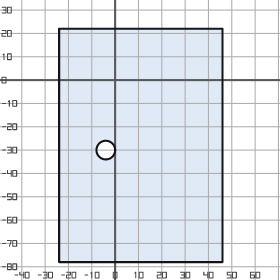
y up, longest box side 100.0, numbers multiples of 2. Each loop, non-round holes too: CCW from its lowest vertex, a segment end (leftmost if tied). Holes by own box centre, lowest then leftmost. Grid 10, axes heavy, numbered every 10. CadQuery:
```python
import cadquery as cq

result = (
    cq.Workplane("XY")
    .moveTo(-24.0, -78.0)
    .lineTo(46.0, -78.0)
    .lineTo(46.0, 22.0)
    .lineTo(-24.0, 22.0)
    .close()
    .moveTo(-4.0, -30.0)
    .circle(4.0)
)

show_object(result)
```